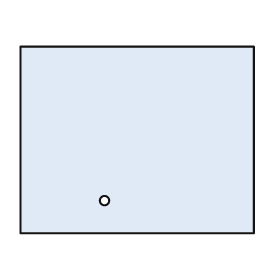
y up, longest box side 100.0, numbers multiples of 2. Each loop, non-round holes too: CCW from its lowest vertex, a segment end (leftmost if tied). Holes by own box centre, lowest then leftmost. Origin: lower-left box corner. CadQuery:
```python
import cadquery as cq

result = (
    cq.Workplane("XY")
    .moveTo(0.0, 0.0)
    .lineTo(100.0, 0.0)
    .lineTo(100.0, 80.0)
    .lineTo(0.0, 80.0)
    .close()
    .moveTo(36.0, 14.0)
    .circle(2.0)
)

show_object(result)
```